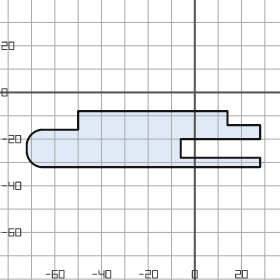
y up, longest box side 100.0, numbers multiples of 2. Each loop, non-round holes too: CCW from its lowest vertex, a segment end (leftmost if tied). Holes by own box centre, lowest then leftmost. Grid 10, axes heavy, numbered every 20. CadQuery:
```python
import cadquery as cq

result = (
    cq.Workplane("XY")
    .moveTo(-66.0, -32.0)
    .lineTo(28.0, -32.0)
    .lineTo(28.0, -28.0)
    .lineTo(-6.0, -28.0)
    .lineTo(-6.0, -20.0)
    .lineTo(28.0, -20.0)
    .lineTo(28.0, -14.0)
    .lineTo(14.0, -14.0)
    .lineTo(14.0, -8.0)
    .lineTo(-50.0, -8.0)
    .lineTo(-50.0, -16.0)
    .lineTo(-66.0, -16.0)
    .threePointArc((-70.0, -18.0), (-72.0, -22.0))
    .lineTo(-72.0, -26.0)
    .threePointArc((-70.0, -30.0), (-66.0, -32.0))
    .close()
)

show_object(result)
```